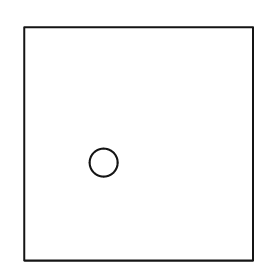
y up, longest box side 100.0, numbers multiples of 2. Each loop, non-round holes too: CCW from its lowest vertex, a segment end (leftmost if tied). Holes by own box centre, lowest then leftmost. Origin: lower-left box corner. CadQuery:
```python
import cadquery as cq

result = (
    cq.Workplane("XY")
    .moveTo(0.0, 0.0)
    .lineTo(98.0, 0.0)
    .lineTo(98.0, 100.0)
    .lineTo(0.0, 100.0)
    .close()
    .moveTo(34.0, 42.0)
    .circle(6.0)
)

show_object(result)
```